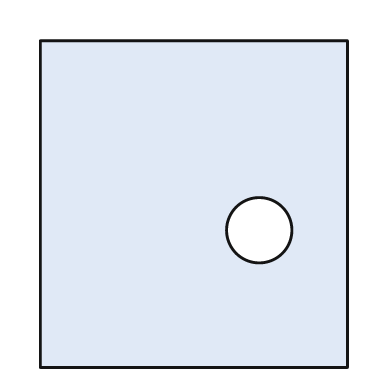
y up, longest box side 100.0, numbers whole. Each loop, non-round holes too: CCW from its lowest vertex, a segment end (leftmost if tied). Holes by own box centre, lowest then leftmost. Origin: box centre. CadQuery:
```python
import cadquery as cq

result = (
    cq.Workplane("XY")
    .moveTo(-47.0, -50.0)
    .lineTo(47.0, -50.0)
    .lineTo(47.0, 50.0)
    .lineTo(-47.0, 50.0)
    .close()
    .moveTo(20.0, -8.0)
    .circle(10.0)
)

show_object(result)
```